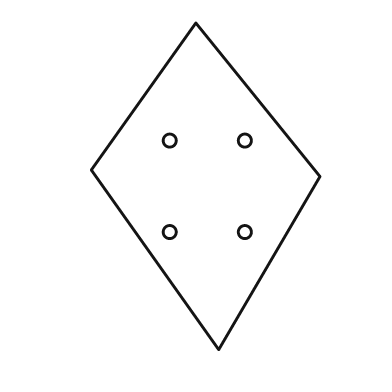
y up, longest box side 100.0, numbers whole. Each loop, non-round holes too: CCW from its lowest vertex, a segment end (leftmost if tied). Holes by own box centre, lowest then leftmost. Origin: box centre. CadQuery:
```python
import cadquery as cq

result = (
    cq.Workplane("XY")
    .moveTo(4.0, -50.0)
    .lineTo(35.0, 3.0)
    .lineTo(-3.0, 50.0)
    .lineTo(-35.0, 5.0)
    .close()
    .moveTo(-11.0, -14.0)
    .circle(2.0)
    .moveTo(12.0, -14.0)
    .circle(2.0)
    .moveTo(-11.0, 14.0)
    .circle(2.0)
    .moveTo(12.0, 14.0)
    .circle(2.0)
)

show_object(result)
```